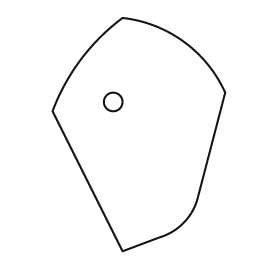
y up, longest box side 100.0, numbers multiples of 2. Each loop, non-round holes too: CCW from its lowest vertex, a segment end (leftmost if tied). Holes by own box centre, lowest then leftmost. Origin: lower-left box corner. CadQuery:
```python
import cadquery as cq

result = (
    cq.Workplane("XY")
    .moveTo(30.0, 0.0)
    .lineTo(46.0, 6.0)
    .threePointArc((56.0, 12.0), (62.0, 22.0))
    .lineTo(74.0, 68.0)
    .threePointArc((56.0, 90.0), (30.0, 100.0))
    .threePointArc((12.0, 82.0), (0.0, 60.0))
    .close()
    .moveTo(26.0, 64.0)
    .circle(4.0)
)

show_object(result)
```